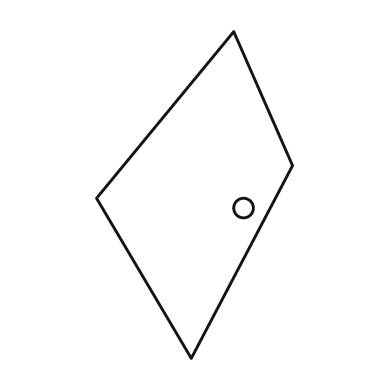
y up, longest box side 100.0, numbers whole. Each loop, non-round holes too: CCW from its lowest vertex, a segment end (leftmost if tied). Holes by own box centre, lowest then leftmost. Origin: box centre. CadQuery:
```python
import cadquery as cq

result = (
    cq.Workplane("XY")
    .moveTo(-1.0, -50.0)
    .lineTo(30.0, 9.0)
    .lineTo(12.0, 50.0)
    .lineTo(-30.0, -1.0)
    .close()
    .moveTo(15.0, -4.0)
    .circle(3.0)
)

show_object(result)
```